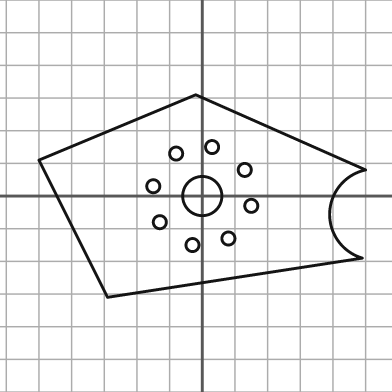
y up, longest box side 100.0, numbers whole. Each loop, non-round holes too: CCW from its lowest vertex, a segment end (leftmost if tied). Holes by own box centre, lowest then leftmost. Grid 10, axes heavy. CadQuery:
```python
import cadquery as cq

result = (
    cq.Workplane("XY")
    .moveTo(-29.0, -31.0)
    .lineTo(49.0, -19.0)
    .threePointArc((39.0, -5.0), (50.0, 8.0))
    .lineTo(-2.0, 31.0)
    .lineTo(-50.0, 11.0)
    .close()
    .moveTo(-3.0, -15.0)
    .circle(2.0)
    .moveTo(8.0, -13.0)
    .circle(2.0)
    .moveTo(-13.0, -8.0)
    .circle(2.0)
    .moveTo(15.0, -3.0)
    .circle(2.0)
    .moveTo(0.0, 0.0)
    .circle(6.0)
    .moveTo(-15.0, 3.0)
    .circle(2.0)
    .moveTo(13.0, 8.0)
    .circle(2.0)
    .moveTo(-8.0, 13.0)
    .circle(2.0)
    .moveTo(3.0, 15.0)
    .circle(2.0)
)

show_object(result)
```